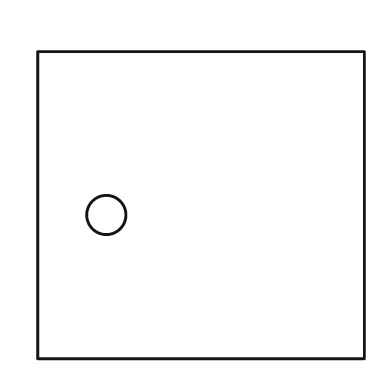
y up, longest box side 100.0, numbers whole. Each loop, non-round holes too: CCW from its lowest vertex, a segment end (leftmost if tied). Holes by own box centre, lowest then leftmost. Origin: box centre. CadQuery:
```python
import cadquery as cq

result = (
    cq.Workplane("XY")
    .moveTo(-50.0, -47.0)
    .lineTo(50.0, -47.0)
    .lineTo(50.0, 47.0)
    .lineTo(-50.0, 47.0)
    .close()
    .moveTo(-29.0, -3.0)
    .circle(6.0)
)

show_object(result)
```